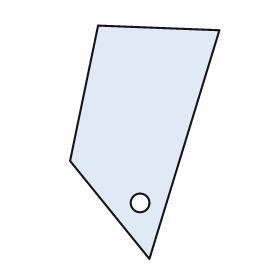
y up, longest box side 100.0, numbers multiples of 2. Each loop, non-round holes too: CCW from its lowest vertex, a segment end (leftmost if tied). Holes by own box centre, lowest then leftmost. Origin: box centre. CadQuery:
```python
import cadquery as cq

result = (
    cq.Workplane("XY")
    .moveTo(2.0, -50.0)
    .lineTo(32.0, 48.0)
    .lineTo(-20.0, 50.0)
    .lineTo(-32.0, -8.0)
    .close()
    .moveTo(-2.0, -26.0)
    .circle(4.0)
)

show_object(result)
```